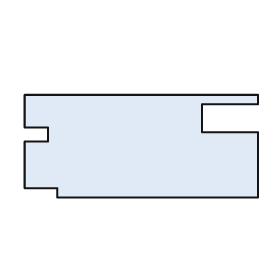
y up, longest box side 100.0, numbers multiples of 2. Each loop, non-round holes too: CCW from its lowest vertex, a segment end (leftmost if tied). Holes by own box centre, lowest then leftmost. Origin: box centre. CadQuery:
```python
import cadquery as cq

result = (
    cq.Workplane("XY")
    .moveTo(-36.0, -22.0)
    .lineTo(50.0, -22.0)
    .lineTo(50.0, 6.0)
    .lineTo(26.0, 6.0)
    .lineTo(26.0, 18.0)
    .lineTo(50.0, 18.0)
    .lineTo(50.0, 22.0)
    .lineTo(-50.0, 22.0)
    .lineTo(-50.0, 8.0)
    .lineTo(-40.0, 8.0)
    .lineTo(-40.0, 2.0)
    .lineTo(-50.0, 2.0)
    .lineTo(-50.0, -18.0)
    .lineTo(-36.0, -18.0)
    .close()
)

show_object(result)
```